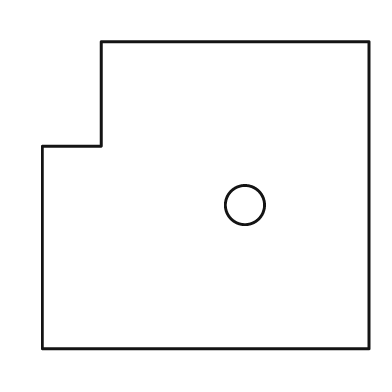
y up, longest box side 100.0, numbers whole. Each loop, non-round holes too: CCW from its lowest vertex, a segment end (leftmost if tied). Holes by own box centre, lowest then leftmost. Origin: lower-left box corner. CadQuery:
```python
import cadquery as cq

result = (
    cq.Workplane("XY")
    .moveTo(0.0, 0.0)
    .lineTo(100.0, 0.0)
    .lineTo(100.0, 94.0)
    .lineTo(18.0, 94.0)
    .lineTo(18.0, 62.0)
    .lineTo(0.0, 62.0)
    .close()
    .moveTo(62.0, 44.0)
    .circle(6.0)
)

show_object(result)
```